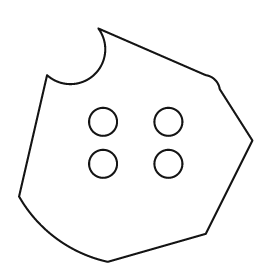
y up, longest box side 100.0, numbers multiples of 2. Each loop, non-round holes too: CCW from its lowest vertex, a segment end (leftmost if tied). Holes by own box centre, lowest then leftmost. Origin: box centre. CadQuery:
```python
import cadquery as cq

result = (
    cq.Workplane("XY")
    .moveTo(-12.0, -50.0)
    .lineTo(30.0, -38.0)
    .lineTo(50.0, 2.0)
    .lineTo(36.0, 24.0)
    .threePointArc((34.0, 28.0), (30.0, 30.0))
    .lineTo(-16.0, 50.0)
    .threePointArc((-18.0, 30.0), (-38.0, 30.0))
    .lineTo(-50.0, -22.0)
    .threePointArc((-34.0, -40.0), (-12.0, -50.0))
    .close()
    .moveTo(-14.0, -8.0)
    .circle(6.0)
    .moveTo(14.0, -8.0)
    .circle(6.0)
    .moveTo(-14.0, 10.0)
    .circle(6.0)
    .moveTo(14.0, 10.0)
    .circle(6.0)
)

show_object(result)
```